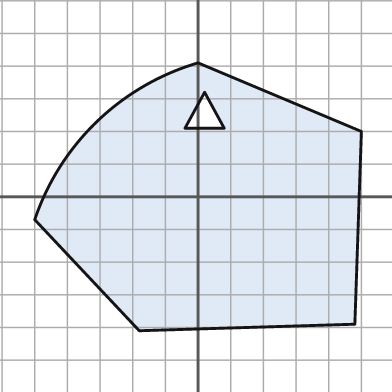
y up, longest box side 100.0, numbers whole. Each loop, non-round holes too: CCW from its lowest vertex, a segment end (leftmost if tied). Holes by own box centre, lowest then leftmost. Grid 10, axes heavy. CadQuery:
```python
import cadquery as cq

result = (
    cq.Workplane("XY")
    .moveTo(-18.0, -41.0)
    .lineTo(48.0, -39.0)
    .lineTo(50.0, 20.0)
    .lineTo(0.0, 41.0)
    .threePointArc((-31.0, 23.0), (-50.0, -7.0))
    .close()
    .moveTo(-4.0, 21.0)
    .lineTo(8.0, 21.0)
    .lineTo(2.0, 32.0)
    .close()
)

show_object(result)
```